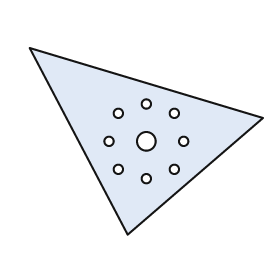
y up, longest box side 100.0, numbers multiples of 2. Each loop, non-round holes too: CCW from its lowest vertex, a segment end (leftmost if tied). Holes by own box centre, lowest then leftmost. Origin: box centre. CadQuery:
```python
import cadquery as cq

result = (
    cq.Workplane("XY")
    .moveTo(-8.0, -40.0)
    .lineTo(50.0, 10.0)
    .lineTo(-50.0, 40.0)
    .close()
    .moveTo(0.0, -16.0)
    .circle(2.0)
    .moveTo(-12.0, -12.0)
    .circle(2.0)
    .moveTo(12.0, -12.0)
    .circle(2.0)
    .moveTo(-16.0, 0.0)
    .circle(2.0)
    .moveTo(0.0, 0.0)
    .circle(4.0)
    .moveTo(16.0, 0.0)
    .circle(2.0)
    .moveTo(-12.0, 12.0)
    .circle(2.0)
    .moveTo(12.0, 12.0)
    .circle(2.0)
    .moveTo(0.0, 16.0)
    .circle(2.0)
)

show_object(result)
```